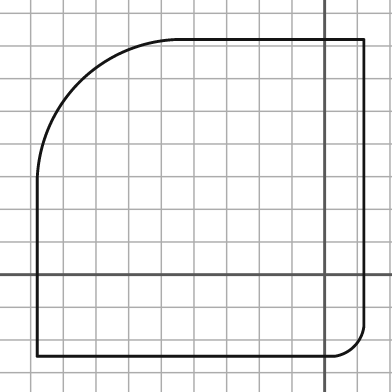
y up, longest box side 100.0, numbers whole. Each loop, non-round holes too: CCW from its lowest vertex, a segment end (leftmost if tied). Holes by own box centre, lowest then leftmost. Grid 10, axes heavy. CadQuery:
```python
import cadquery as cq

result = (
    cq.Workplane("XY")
    .moveTo(-88.0, -25.0)
    .lineTo(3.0, -25.0)
    .threePointArc((9.0, -22.0), (12.0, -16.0))
    .lineTo(12.0, 72.0)
    .lineTo(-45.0, 72.0)
    .threePointArc((-75.0, 59.0), (-88.0, 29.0))
    .close()
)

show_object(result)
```